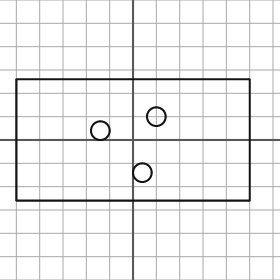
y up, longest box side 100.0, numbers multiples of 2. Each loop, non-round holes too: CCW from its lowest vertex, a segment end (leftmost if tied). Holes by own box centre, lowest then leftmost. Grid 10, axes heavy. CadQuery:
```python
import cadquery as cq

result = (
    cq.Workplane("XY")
    .moveTo(-50.0, -26.0)
    .lineTo(50.0, -26.0)
    .lineTo(50.0, 26.0)
    .lineTo(-50.0, 26.0)
    .close()
    .moveTo(4.0, -14.0)
    .circle(4.0)
    .moveTo(-14.0, 4.0)
    .circle(4.0)
    .moveTo(10.0, 10.0)
    .circle(4.0)
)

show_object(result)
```